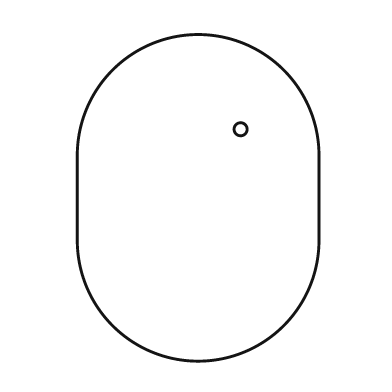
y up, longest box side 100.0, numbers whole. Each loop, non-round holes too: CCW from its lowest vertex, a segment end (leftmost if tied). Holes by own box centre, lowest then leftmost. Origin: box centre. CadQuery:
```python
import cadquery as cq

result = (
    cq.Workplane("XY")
    .moveTo(-37.0, -13.0)
    .threePointArc((0.0, -50.0), (37.0, -13.0))
    .lineTo(37.0, 13.0)
    .threePointArc((0.0, 50.0), (-37.0, 13.0))
    .close()
    .moveTo(13.0, 21.0)
    .circle(2.0)
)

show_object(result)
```